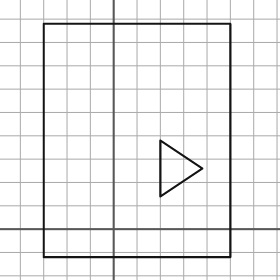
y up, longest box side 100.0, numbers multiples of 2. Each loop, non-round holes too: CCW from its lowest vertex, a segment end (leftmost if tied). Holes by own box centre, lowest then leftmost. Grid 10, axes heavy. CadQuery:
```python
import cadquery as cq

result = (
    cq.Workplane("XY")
    .moveTo(-30.0, -12.0)
    .lineTo(50.0, -12.0)
    .lineTo(50.0, 88.0)
    .lineTo(-30.0, 88.0)
    .close()
    .moveTo(20.0, 14.0)
    .lineTo(38.0, 26.0)
    .lineTo(20.0, 38.0)
    .close()
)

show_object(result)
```